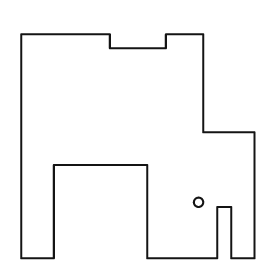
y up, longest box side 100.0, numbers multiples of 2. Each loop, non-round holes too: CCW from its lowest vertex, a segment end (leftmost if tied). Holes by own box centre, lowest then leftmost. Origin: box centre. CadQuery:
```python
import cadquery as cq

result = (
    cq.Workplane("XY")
    .moveTo(-50.0, -48.0)
    .lineTo(-36.0, -48.0)
    .lineTo(-36.0, -8.0)
    .lineTo(4.0, -8.0)
    .lineTo(4.0, -48.0)
    .lineTo(34.0, -48.0)
    .lineTo(34.0, -26.0)
    .lineTo(40.0, -26.0)
    .lineTo(40.0, -48.0)
    .lineTo(50.0, -48.0)
    .lineTo(50.0, 6.0)
    .lineTo(28.0, 6.0)
    .lineTo(28.0, 48.0)
    .lineTo(12.0, 48.0)
    .lineTo(12.0, 42.0)
    .lineTo(-12.0, 42.0)
    .lineTo(-12.0, 48.0)
    .lineTo(-50.0, 48.0)
    .close()
    .moveTo(26.0, -24.0)
    .circle(2.0)
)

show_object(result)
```